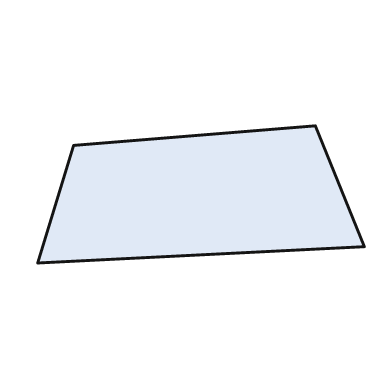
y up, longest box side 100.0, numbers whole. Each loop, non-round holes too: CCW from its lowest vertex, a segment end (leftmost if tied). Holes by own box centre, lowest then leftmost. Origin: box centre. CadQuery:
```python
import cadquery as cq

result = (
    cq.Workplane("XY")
    .moveTo(-50.0, -21.0)
    .lineTo(50.0, -16.0)
    .lineTo(35.0, 21.0)
    .lineTo(-39.0, 15.0)
    .close()
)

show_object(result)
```